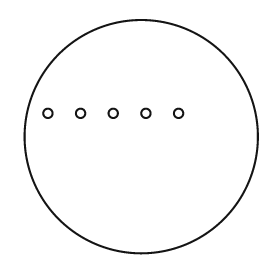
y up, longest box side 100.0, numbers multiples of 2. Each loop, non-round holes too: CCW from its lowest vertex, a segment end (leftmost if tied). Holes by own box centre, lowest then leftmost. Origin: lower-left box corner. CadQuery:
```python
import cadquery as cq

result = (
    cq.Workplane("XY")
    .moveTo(50.0, 50.0)
    .circle(50.0)
    .moveTo(10.0, 60.0)
    .circle(2.0)
    .moveTo(24.0, 60.0)
    .circle(2.0)
    .moveTo(38.0, 60.0)
    .circle(2.0)
    .moveTo(52.0, 60.0)
    .circle(2.0)
    .moveTo(66.0, 60.0)
    .circle(2.0)
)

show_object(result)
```